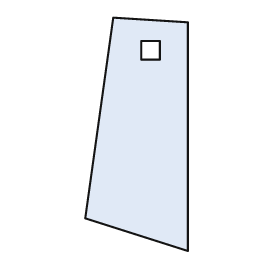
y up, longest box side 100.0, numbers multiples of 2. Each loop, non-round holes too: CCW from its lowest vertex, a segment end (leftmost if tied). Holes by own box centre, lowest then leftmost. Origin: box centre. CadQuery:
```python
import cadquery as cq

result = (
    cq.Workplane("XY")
    .moveTo(22.0, -50.0)
    .lineTo(22.0, 48.0)
    .lineTo(-10.0, 50.0)
    .lineTo(-22.0, -36.0)
    .close()
    .moveTo(2.0, 32.0)
    .lineTo(10.0, 32.0)
    .lineTo(10.0, 40.0)
    .lineTo(2.0, 40.0)
    .close()
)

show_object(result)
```